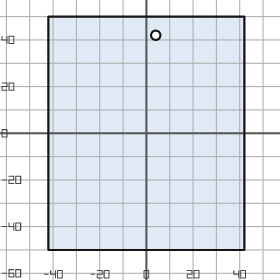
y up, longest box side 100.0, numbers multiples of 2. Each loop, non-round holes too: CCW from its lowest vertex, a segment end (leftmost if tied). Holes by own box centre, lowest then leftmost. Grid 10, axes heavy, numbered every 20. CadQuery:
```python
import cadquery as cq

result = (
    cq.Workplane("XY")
    .moveTo(-42.0, -50.0)
    .lineTo(42.0, -50.0)
    .lineTo(42.0, 50.0)
    .lineTo(-42.0, 50.0)
    .close()
    .moveTo(4.0, 42.0)
    .circle(2.0)
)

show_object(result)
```